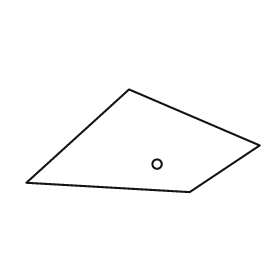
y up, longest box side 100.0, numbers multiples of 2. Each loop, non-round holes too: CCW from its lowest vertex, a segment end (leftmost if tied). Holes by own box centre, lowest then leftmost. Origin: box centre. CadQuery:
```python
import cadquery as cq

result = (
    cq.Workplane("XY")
    .moveTo(20.0, -22.0)
    .lineTo(50.0, -2.0)
    .lineTo(-6.0, 22.0)
    .lineTo(-50.0, -18.0)
    .close()
    .moveTo(6.0, -10.0)
    .circle(2.0)
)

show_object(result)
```